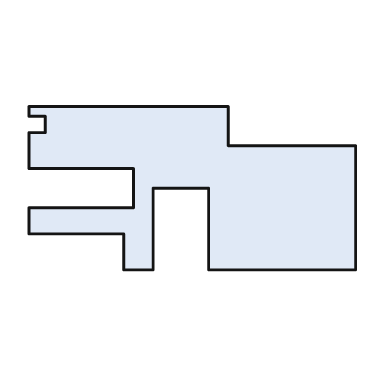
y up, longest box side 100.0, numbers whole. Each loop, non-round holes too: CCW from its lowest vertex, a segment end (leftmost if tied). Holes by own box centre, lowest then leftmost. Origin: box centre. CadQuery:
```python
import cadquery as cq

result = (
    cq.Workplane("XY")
    .moveTo(-21.0, -25.0)
    .lineTo(-12.0, -25.0)
    .lineTo(-12.0, 0.0)
    .lineTo(5.0, 0.0)
    .lineTo(5.0, -25.0)
    .lineTo(50.0, -25.0)
    .lineTo(50.0, 13.0)
    .lineTo(11.0, 13.0)
    .lineTo(11.0, 25.0)
    .lineTo(-50.0, 25.0)
    .lineTo(-50.0, 22.0)
    .lineTo(-45.0, 22.0)
    .lineTo(-45.0, 17.0)
    .lineTo(-50.0, 17.0)
    .lineTo(-50.0, 6.0)
    .lineTo(-18.0, 6.0)
    .lineTo(-18.0, -6.0)
    .lineTo(-50.0, -6.0)
    .lineTo(-50.0, -14.0)
    .lineTo(-21.0, -14.0)
    .close()
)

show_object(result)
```